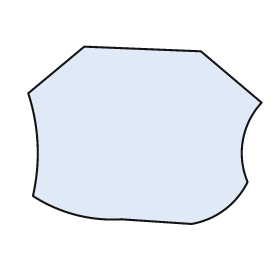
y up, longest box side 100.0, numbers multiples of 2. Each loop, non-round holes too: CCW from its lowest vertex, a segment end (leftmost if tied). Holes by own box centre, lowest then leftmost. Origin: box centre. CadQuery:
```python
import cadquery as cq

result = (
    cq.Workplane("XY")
    .moveTo(20.0, -38.0)
    .threePointArc((34.0, -32.0), (44.0, -20.0))
    .threePointArc((42.0, -2.0), (50.0, 14.0))
    .lineTo(24.0, 36.0)
    .lineTo(-26.0, 38.0)
    .lineTo(-50.0, 18.0)
    .threePointArc((-46.0, -4.0), (-48.0, -26.0))
    .threePointArc((-30.0, -34.0), (-10.0, -36.0))
    .close()
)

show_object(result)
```